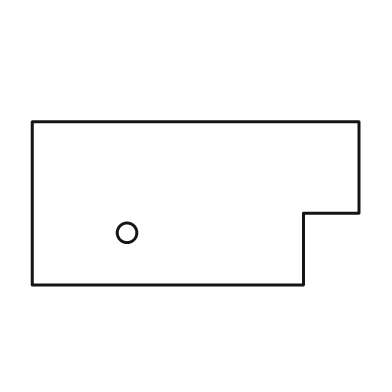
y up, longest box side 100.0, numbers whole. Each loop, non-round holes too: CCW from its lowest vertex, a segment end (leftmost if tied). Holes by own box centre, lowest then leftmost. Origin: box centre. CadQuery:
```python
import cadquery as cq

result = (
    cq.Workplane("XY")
    .moveTo(-50.0, -25.0)
    .lineTo(33.0, -25.0)
    .lineTo(33.0, -3.0)
    .lineTo(50.0, -3.0)
    .lineTo(50.0, 25.0)
    .lineTo(-50.0, 25.0)
    .close()
    .moveTo(-21.0, -9.0)
    .circle(3.0)
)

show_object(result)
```